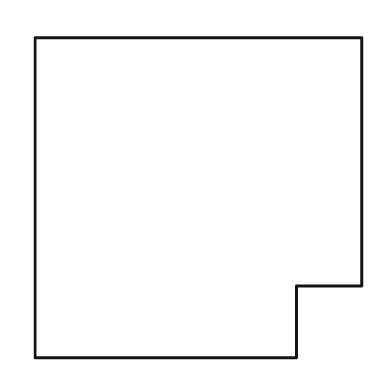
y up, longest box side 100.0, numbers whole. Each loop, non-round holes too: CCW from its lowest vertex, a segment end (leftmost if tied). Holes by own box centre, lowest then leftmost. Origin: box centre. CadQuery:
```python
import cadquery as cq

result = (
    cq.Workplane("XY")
    .moveTo(-50.0, -49.0)
    .lineTo(30.0, -49.0)
    .lineTo(30.0, -27.0)
    .lineTo(50.0, -27.0)
    .lineTo(50.0, 49.0)
    .lineTo(-50.0, 49.0)
    .close()
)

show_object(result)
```